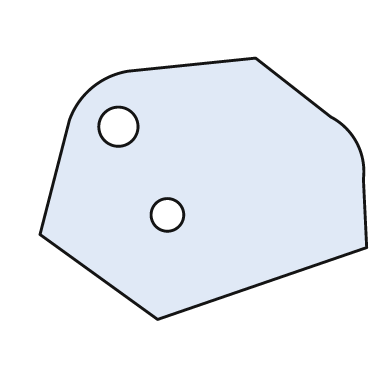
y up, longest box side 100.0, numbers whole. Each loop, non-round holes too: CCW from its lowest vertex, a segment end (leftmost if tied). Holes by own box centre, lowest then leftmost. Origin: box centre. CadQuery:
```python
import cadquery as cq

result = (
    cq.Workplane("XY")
    .moveTo(-14.0, -40.0)
    .lineTo(50.0, -18.0)
    .lineTo(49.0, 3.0)
    .threePointArc((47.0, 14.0), (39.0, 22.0))
    .lineTo(16.0, 40.0)
    .lineTo(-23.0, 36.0)
    .threePointArc((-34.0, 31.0), (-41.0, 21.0))
    .lineTo(-50.0, -14.0)
    .close()
    .moveTo(-11.0, -8.0)
    .circle(5.0)
    .moveTo(-26.0, 19.0)
    .circle(6.0)
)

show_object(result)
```